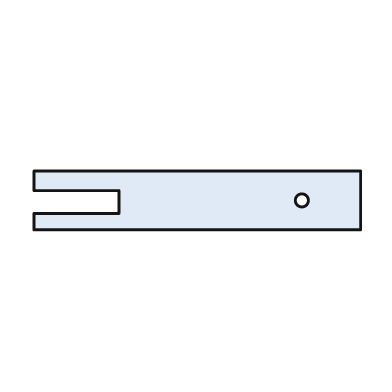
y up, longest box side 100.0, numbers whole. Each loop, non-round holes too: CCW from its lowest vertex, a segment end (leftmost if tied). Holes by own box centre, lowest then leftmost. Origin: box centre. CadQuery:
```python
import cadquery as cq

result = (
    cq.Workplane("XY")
    .moveTo(-50.0, -9.0)
    .lineTo(50.0, -9.0)
    .lineTo(50.0, 9.0)
    .lineTo(-50.0, 9.0)
    .lineTo(-50.0, 3.0)
    .lineTo(-24.0, 3.0)
    .lineTo(-24.0, -4.0)
    .lineTo(-50.0, -4.0)
    .close()
    .moveTo(32.0, 0.0)
    .circle(2.0)
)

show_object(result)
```